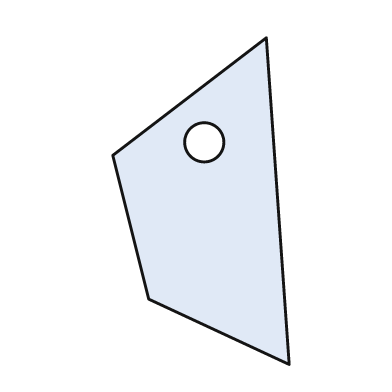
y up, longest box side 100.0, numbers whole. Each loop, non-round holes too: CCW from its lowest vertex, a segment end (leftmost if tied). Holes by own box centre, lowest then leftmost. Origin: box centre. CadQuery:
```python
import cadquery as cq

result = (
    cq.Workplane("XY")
    .moveTo(27.0, -50.0)
    .lineTo(20.0, 50.0)
    .lineTo(-27.0, 14.0)
    .lineTo(-16.0, -30.0)
    .close()
    .moveTo(1.0, 18.0)
    .circle(6.0)
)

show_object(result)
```